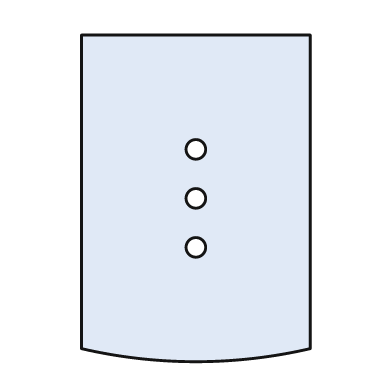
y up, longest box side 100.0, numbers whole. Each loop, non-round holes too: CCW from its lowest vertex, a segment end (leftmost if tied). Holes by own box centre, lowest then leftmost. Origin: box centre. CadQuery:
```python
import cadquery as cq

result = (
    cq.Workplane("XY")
    .moveTo(-35.0, -46.0)
    .threePointArc((0.0, -50.0), (35.0, -46.0))
    .lineTo(35.0, 50.0)
    .lineTo(-35.0, 50.0)
    .close()
    .moveTo(0.0, -15.0)
    .circle(3.0)
    .moveTo(0.0, 0.0)
    .circle(3.0)
    .moveTo(0.0, 15.0)
    .circle(3.0)
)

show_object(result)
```